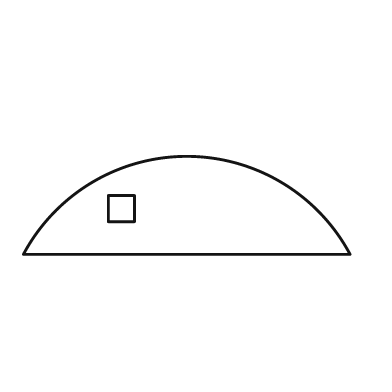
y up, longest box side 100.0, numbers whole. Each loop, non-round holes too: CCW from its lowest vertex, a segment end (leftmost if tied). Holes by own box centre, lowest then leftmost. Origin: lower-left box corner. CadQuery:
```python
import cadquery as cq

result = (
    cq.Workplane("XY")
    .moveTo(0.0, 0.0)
    .lineTo(100.0, 0.0)
    .threePointArc((50.0, 30.0), (0.0, 0.0))
    .close()
    .moveTo(26.0, 10.0)
    .lineTo(34.0, 10.0)
    .lineTo(34.0, 18.0)
    .lineTo(26.0, 18.0)
    .close()
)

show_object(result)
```